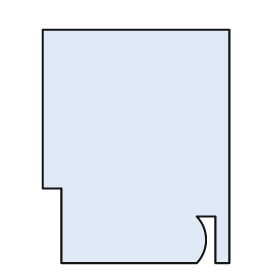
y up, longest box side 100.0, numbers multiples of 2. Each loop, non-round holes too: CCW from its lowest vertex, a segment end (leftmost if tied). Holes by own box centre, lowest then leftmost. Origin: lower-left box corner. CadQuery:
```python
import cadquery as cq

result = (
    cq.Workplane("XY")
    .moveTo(8.0, 0.0)
    .lineTo(66.0, 0.0)
    .threePointArc((70.0, 10.0), (66.0, 20.0))
    .lineTo(74.0, 20.0)
    .lineTo(74.0, 0.0)
    .lineTo(80.0, 0.0)
    .lineTo(80.0, 100.0)
    .lineTo(0.0, 100.0)
    .lineTo(0.0, 32.0)
    .lineTo(8.0, 32.0)
    .close()
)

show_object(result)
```